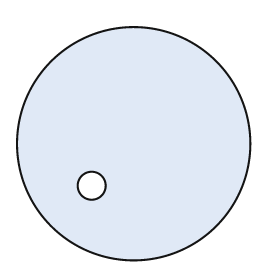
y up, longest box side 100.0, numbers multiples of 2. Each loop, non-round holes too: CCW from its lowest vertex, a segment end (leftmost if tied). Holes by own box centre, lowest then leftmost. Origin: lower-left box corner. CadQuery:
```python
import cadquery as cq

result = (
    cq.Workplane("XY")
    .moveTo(50.0, 50.0)
    .circle(50.0)
    .moveTo(32.0, 32.0)
    .circle(6.0)
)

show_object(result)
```